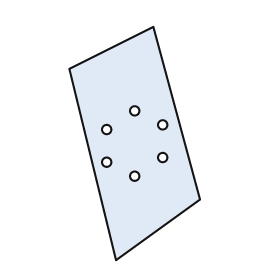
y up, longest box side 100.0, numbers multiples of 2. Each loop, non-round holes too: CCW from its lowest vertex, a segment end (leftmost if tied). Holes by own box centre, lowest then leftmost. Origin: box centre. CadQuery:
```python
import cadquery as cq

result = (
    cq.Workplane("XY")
    .moveTo(-8.0, -50.0)
    .lineTo(28.0, -24.0)
    .lineTo(8.0, 50.0)
    .lineTo(-28.0, 32.0)
    .close()
    .moveTo(0.0, -14.0)
    .circle(2.0)
    .moveTo(-12.0, -8.0)
    .circle(2.0)
    .moveTo(12.0, -6.0)
    .circle(2.0)
    .moveTo(-12.0, 6.0)
    .circle(2.0)
    .moveTo(12.0, 8.0)
    .circle(2.0)
    .moveTo(0.0, 14.0)
    .circle(2.0)
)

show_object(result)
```